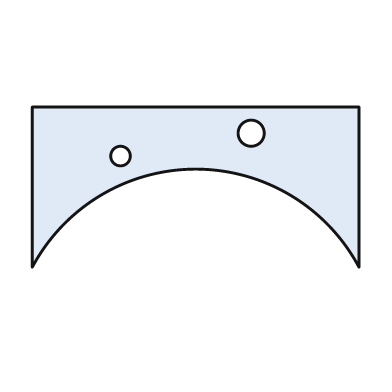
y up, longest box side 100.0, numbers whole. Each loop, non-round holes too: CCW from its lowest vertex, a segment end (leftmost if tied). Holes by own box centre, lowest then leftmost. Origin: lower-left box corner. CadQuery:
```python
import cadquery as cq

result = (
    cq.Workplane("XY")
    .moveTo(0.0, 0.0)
    .threePointArc((50.0, 30.0), (100.0, 0.0))
    .lineTo(100.0, 49.0)
    .lineTo(0.0, 49.0)
    .close()
    .moveTo(27.0, 34.0)
    .circle(3.0)
    .moveTo(67.0, 41.0)
    .circle(4.0)
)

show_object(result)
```